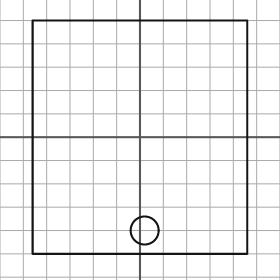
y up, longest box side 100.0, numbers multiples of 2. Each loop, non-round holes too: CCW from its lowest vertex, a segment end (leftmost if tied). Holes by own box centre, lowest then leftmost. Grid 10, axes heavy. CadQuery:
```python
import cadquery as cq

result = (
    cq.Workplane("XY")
    .moveTo(-46.0, -50.0)
    .lineTo(46.0, -50.0)
    .lineTo(46.0, 50.0)
    .lineTo(-46.0, 50.0)
    .close()
    .moveTo(2.0, -40.0)
    .circle(6.0)
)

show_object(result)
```